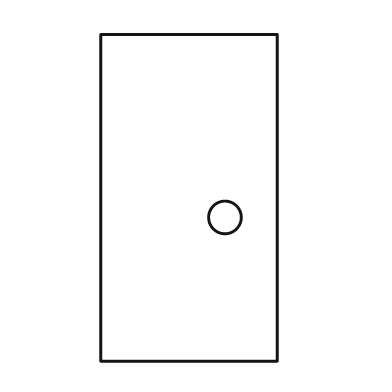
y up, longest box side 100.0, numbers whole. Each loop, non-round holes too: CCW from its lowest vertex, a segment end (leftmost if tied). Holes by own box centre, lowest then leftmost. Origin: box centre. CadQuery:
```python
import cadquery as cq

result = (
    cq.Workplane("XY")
    .moveTo(-27.0, -50.0)
    .lineTo(27.0, -50.0)
    .lineTo(27.0, 50.0)
    .lineTo(-27.0, 50.0)
    .close()
    .moveTo(11.0, -6.0)
    .circle(5.0)
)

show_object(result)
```